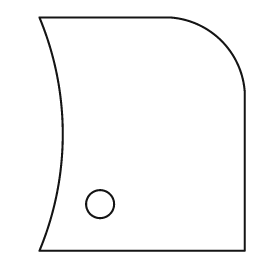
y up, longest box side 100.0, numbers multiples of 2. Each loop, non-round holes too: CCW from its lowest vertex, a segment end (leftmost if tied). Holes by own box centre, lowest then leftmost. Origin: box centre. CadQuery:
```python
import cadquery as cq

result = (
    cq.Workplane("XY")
    .moveTo(-44.0, -50.0)
    .lineTo(44.0, -50.0)
    .lineTo(44.0, 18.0)
    .threePointArc((34.0, 40.0), (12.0, 50.0))
    .lineTo(-44.0, 50.0)
    .threePointArc((-34.0, 0.0), (-44.0, -50.0))
    .close()
    .moveTo(-18.0, -30.0)
    .circle(6.0)
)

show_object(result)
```